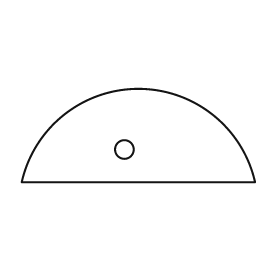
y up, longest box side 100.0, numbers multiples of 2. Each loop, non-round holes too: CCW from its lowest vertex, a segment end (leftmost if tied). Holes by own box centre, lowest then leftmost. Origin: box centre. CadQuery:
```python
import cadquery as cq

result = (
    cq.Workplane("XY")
    .moveTo(-50.0, -20.0)
    .lineTo(50.0, -20.0)
    .threePointArc((0.0, 20.0), (-50.0, -20.0))
    .close()
    .moveTo(-6.0, -6.0)
    .circle(4.0)
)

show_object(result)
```